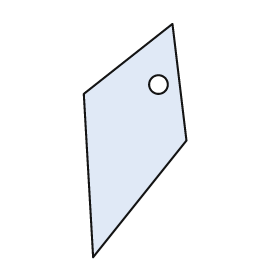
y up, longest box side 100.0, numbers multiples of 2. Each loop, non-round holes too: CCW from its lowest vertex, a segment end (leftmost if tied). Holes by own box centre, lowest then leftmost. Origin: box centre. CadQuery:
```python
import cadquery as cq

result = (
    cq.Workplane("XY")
    .moveTo(-18.0, -50.0)
    .lineTo(22.0, 0.0)
    .lineTo(16.0, 50.0)
    .lineTo(-22.0, 20.0)
    .close()
    .moveTo(10.0, 24.0)
    .circle(4.0)
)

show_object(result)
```